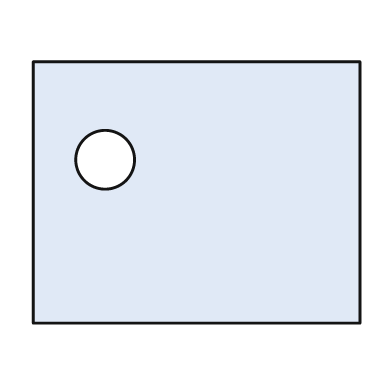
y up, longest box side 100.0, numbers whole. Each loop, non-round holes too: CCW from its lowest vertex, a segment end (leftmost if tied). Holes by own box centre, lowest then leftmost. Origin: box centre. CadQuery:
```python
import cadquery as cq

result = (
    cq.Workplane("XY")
    .moveTo(-50.0, -40.0)
    .lineTo(50.0, -40.0)
    .lineTo(50.0, 40.0)
    .lineTo(-50.0, 40.0)
    .close()
    .moveTo(-28.0, 10.0)
    .circle(9.0)
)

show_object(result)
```